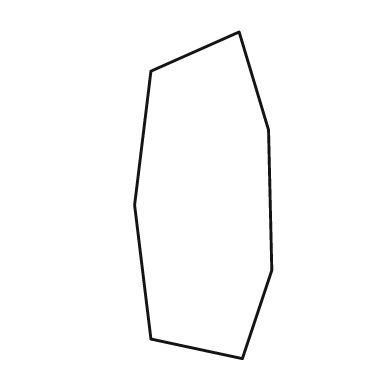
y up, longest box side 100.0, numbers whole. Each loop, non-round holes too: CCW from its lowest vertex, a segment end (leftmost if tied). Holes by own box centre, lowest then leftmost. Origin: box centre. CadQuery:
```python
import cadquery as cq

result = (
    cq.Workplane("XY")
    .moveTo(12.0, -50.0)
    .lineTo(21.0, -23.0)
    .lineTo(20.0, 20.0)
    .lineTo(11.0, 50.0)
    .lineTo(-16.0, 38.0)
    .lineTo(-21.0, -3.0)
    .lineTo(-16.0, -44.0)
    .close()
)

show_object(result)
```